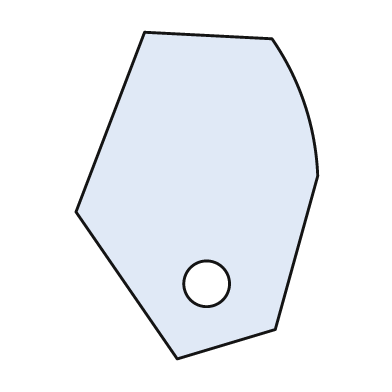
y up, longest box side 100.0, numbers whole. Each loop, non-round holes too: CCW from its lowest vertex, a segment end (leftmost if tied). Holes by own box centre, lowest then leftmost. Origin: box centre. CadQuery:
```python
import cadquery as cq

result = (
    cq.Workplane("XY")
    .moveTo(-6.0, -50.0)
    .lineTo(24.0, -41.0)
    .lineTo(37.0, 6.0)
    .threePointArc((33.0, 28.0), (23.0, 48.0))
    .lineTo(-16.0, 50.0)
    .lineTo(-37.0, -5.0)
    .close()
    .moveTo(3.0, -27.0)
    .circle(7.0)
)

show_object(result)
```